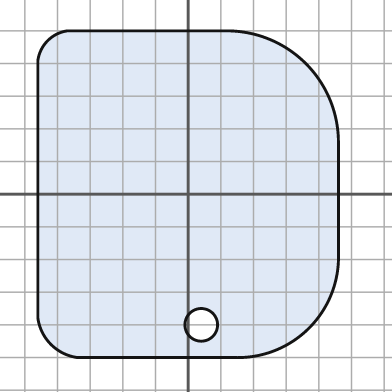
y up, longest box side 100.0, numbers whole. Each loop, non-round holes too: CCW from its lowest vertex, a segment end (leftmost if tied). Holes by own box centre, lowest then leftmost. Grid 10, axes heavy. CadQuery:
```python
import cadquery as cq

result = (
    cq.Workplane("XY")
    .moveTo(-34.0, -50.0)
    .lineTo(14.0, -50.0)
    .threePointArc((37.0, -41.0), (46.0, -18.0))
    .lineTo(46.0, 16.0)
    .threePointArc((36.0, 40.0), (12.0, 50.0))
    .lineTo(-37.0, 50.0)
    .threePointArc((-43.0, 47.0), (-46.0, 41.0))
    .lineTo(-46.0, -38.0)
    .threePointArc((-42.0, -46.0), (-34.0, -50.0))
    .close()
    .moveTo(4.0, -40.0)
    .circle(5.0)
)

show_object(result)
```